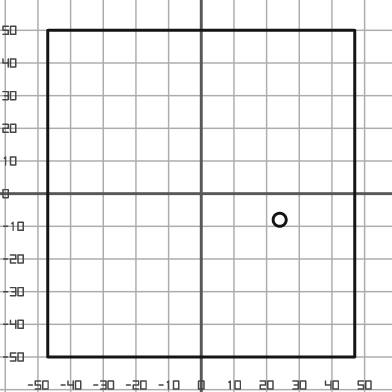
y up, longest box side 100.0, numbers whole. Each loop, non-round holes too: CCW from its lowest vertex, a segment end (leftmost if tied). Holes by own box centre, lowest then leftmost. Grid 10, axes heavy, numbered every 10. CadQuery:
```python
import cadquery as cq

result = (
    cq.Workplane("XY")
    .moveTo(-47.0, -50.0)
    .lineTo(47.0, -50.0)
    .lineTo(47.0, 50.0)
    .lineTo(-47.0, 50.0)
    .close()
    .moveTo(24.0, -8.0)
    .circle(2.0)
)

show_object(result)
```